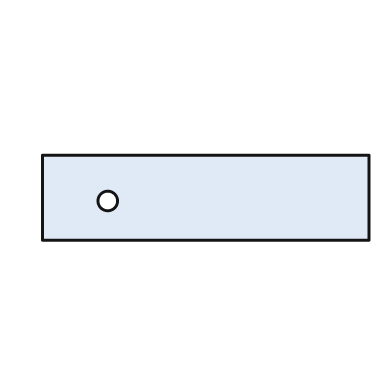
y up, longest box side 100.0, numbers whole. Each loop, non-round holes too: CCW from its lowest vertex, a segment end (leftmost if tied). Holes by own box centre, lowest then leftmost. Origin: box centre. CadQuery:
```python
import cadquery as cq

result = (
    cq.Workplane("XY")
    .moveTo(-50.0, -13.0)
    .lineTo(50.0, -13.0)
    .lineTo(50.0, 13.0)
    .lineTo(-50.0, 13.0)
    .close()
    .moveTo(-30.0, -1.0)
    .circle(3.0)
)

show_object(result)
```